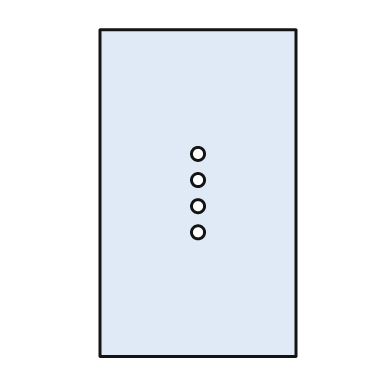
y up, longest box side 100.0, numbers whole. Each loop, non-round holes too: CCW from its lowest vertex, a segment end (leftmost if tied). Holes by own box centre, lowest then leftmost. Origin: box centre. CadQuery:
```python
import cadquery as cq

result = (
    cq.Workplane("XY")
    .moveTo(-30.0, -50.0)
    .lineTo(30.0, -50.0)
    .lineTo(30.0, 50.0)
    .lineTo(-30.0, 50.0)
    .close()
    .moveTo(0.0, -12.0)
    .circle(2.0)
    .moveTo(0.0, -4.0)
    .circle(2.0)
    .moveTo(0.0, 4.0)
    .circle(2.0)
    .moveTo(0.0, 12.0)
    .circle(2.0)
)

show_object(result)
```